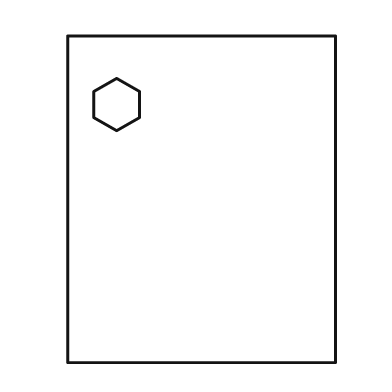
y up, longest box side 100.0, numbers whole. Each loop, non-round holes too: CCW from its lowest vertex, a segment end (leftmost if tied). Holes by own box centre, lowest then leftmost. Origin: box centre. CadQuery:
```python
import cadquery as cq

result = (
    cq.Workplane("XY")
    .moveTo(-41.0, -50.0)
    .lineTo(41.0, -50.0)
    .lineTo(41.0, 50.0)
    .lineTo(-41.0, 50.0)
    .close()
    .moveTo(-26.0, 21.0)
    .lineTo(-19.0, 25.0)
    .lineTo(-19.0, 33.0)
    .lineTo(-26.0, 37.0)
    .lineTo(-33.0, 33.0)
    .lineTo(-33.0, 25.0)
    .close()
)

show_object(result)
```